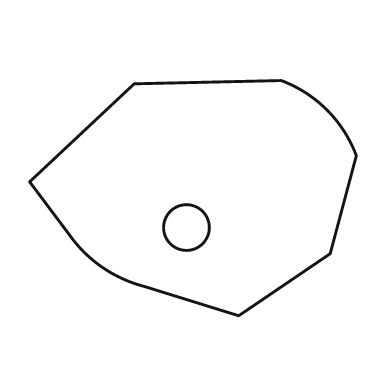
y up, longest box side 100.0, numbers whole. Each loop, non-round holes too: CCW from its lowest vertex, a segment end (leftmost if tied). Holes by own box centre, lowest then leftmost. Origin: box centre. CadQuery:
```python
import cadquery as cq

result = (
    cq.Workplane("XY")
    .moveTo(14.0, -36.0)
    .lineTo(42.0, -17.0)
    .lineTo(50.0, 13.0)
    .threePointArc((41.0, 27.0), (27.0, 36.0))
    .lineTo(-18.0, 35.0)
    .lineTo(-50.0, 5.0)
    .lineTo(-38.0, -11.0)
    .threePointArc((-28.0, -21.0), (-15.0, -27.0))
    .close()
    .moveTo(-2.0, -9.0)
    .circle(7.0)
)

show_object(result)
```